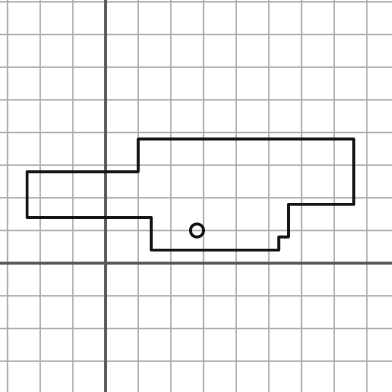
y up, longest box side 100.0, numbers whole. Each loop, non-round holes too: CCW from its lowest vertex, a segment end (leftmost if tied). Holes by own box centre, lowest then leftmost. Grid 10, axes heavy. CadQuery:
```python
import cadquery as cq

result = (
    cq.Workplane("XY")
    .moveTo(14.0, 4.0)
    .lineTo(53.0, 4.0)
    .lineTo(53.0, 8.0)
    .lineTo(56.0, 8.0)
    .lineTo(56.0, 18.0)
    .lineTo(76.0, 18.0)
    .lineTo(76.0, 38.0)
    .lineTo(10.0, 38.0)
    .lineTo(10.0, 28.0)
    .lineTo(-24.0, 28.0)
    .lineTo(-24.0, 14.0)
    .lineTo(14.0, 14.0)
    .close()
    .moveTo(28.0, 10.0)
    .circle(2.0)
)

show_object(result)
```